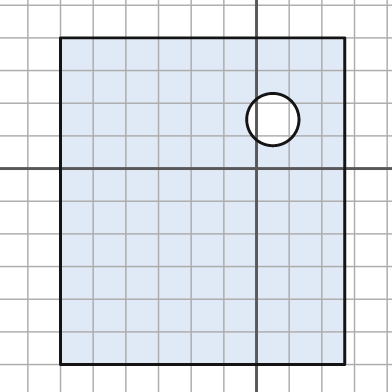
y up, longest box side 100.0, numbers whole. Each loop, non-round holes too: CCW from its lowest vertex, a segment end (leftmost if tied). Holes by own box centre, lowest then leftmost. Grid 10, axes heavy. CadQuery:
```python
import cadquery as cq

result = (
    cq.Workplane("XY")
    .moveTo(-60.0, -60.0)
    .lineTo(27.0, -60.0)
    .lineTo(27.0, 40.0)
    .lineTo(-60.0, 40.0)
    .close()
    .moveTo(5.0, 15.0)
    .circle(8.0)
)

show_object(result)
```